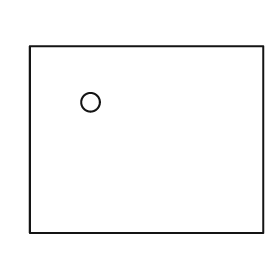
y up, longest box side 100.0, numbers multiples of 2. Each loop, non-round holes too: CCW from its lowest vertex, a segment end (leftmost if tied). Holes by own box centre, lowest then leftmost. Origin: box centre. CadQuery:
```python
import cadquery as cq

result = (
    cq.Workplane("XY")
    .moveTo(-50.0, -40.0)
    .lineTo(50.0, -40.0)
    .lineTo(50.0, 40.0)
    .lineTo(-50.0, 40.0)
    .close()
    .moveTo(-24.0, 16.0)
    .circle(4.0)
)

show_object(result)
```